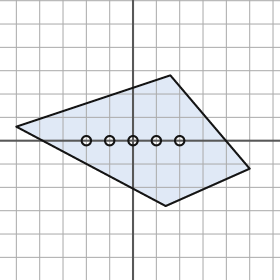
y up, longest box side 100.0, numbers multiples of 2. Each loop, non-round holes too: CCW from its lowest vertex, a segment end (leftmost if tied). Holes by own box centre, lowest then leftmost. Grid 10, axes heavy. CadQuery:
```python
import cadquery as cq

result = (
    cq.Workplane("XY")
    .moveTo(14.0, -28.0)
    .lineTo(50.0, -12.0)
    .lineTo(16.0, 28.0)
    .lineTo(-50.0, 6.0)
    .close()
    .moveTo(-20.0, 0.0)
    .circle(2.0)
    .moveTo(-10.0, 0.0)
    .circle(2.0)
    .moveTo(0.0, 0.0)
    .circle(2.0)
    .moveTo(10.0, 0.0)
    .circle(2.0)
    .moveTo(20.0, 0.0)
    .circle(2.0)
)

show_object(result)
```